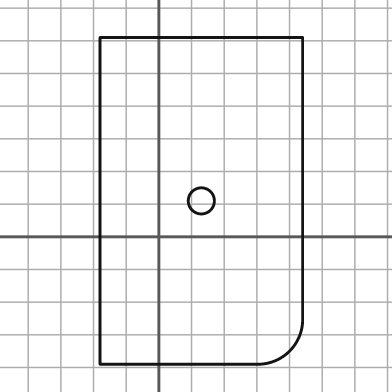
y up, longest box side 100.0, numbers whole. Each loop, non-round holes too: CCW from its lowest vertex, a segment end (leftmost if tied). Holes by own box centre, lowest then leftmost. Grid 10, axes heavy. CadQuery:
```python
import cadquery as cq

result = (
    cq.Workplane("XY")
    .moveTo(-18.0, -39.0)
    .lineTo(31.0, -39.0)
    .threePointArc((40.0, -35.0), (44.0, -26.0))
    .lineTo(44.0, 61.0)
    .lineTo(-18.0, 61.0)
    .close()
    .moveTo(13.0, 11.0)
    .circle(4.0)
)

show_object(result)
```